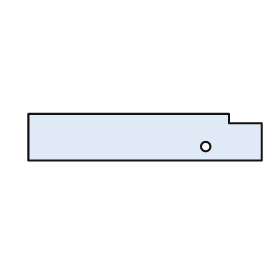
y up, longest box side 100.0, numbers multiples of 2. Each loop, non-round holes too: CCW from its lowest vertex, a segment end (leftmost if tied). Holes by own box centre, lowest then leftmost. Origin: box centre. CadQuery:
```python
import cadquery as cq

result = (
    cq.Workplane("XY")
    .moveTo(-50.0, -10.0)
    .lineTo(50.0, -10.0)
    .lineTo(50.0, 6.0)
    .lineTo(36.0, 6.0)
    .lineTo(36.0, 10.0)
    .lineTo(-50.0, 10.0)
    .close()
    .moveTo(26.0, -4.0)
    .circle(2.0)
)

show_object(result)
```